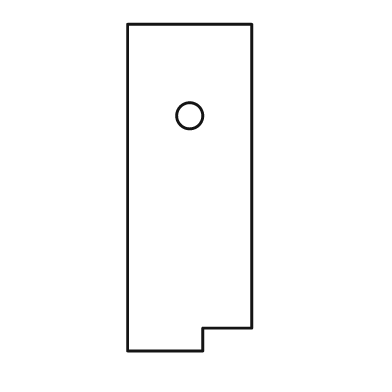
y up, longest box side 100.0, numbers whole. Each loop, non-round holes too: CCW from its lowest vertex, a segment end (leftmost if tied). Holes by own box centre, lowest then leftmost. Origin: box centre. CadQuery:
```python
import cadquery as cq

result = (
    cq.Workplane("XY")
    .moveTo(-19.0, -50.0)
    .lineTo(4.0, -50.0)
    .lineTo(4.0, -43.0)
    .lineTo(19.0, -43.0)
    .lineTo(19.0, 50.0)
    .lineTo(-19.0, 50.0)
    .close()
    .moveTo(0.0, 22.0)
    .circle(4.0)
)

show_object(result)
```